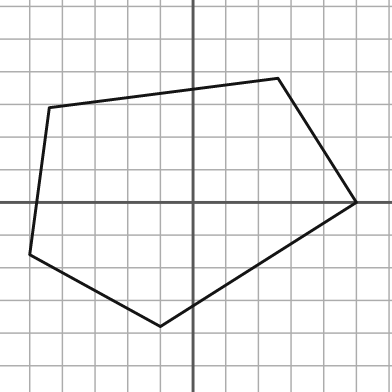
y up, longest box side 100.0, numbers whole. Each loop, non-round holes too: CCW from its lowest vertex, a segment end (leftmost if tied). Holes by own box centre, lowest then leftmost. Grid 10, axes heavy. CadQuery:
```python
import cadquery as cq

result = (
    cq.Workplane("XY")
    .moveTo(-10.0, -38.0)
    .lineTo(50.0, 0.0)
    .lineTo(26.0, 38.0)
    .lineTo(-44.0, 29.0)
    .lineTo(-50.0, -16.0)
    .close()
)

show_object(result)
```